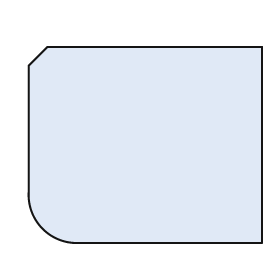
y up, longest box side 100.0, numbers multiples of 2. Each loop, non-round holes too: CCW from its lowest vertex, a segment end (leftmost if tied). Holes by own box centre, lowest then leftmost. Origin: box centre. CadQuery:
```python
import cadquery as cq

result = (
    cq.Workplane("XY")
    .moveTo(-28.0, -42.0)
    .lineTo(50.0, -42.0)
    .lineTo(50.0, 42.0)
    .lineTo(-42.0, 42.0)
    .lineTo(-50.0, 34.0)
    .lineTo(-50.0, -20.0)
    .threePointArc((-44.0, -36.0), (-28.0, -42.0))
    .close()
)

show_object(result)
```